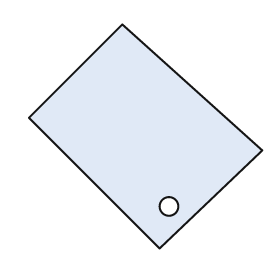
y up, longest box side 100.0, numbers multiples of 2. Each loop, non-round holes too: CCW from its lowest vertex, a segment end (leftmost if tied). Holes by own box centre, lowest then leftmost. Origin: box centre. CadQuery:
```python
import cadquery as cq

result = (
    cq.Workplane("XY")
    .moveTo(6.0, -48.0)
    .lineTo(50.0, -6.0)
    .lineTo(-10.0, 48.0)
    .lineTo(-50.0, 8.0)
    .close()
    .moveTo(10.0, -30.0)
    .circle(4.0)
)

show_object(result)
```